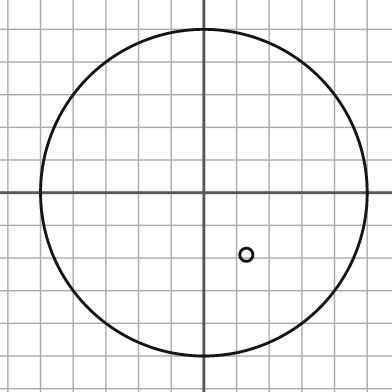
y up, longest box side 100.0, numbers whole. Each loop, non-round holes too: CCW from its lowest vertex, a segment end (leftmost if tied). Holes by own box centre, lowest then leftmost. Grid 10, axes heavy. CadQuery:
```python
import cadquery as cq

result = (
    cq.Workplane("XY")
    .moveTo(0.0, 0.0)
    .circle(50.0)
    .moveTo(13.0, -19.0)
    .circle(2.0)
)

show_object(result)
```